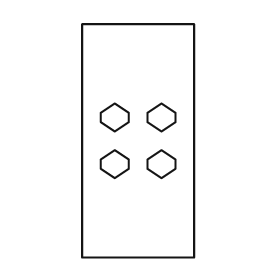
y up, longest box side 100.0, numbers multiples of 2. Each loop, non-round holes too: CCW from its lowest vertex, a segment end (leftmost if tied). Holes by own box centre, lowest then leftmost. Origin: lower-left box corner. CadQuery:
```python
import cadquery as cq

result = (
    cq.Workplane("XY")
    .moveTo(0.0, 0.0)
    .lineTo(48.0, 0.0)
    .lineTo(48.0, 100.0)
    .lineTo(0.0, 100.0)
    .close()
    .moveTo(14.0, 34.0)
    .lineTo(20.0, 38.0)
    .lineTo(20.0, 42.0)
    .lineTo(14.0, 46.0)
    .lineTo(8.0, 42.0)
    .lineTo(8.0, 38.0)
    .close()
    .moveTo(34.0, 34.0)
    .lineTo(40.0, 38.0)
    .lineTo(40.0, 42.0)
    .lineTo(34.0, 46.0)
    .lineTo(28.0, 42.0)
    .lineTo(28.0, 38.0)
    .close()
    .moveTo(14.0, 54.0)
    .lineTo(20.0, 58.0)
    .lineTo(20.0, 62.0)
    .lineTo(14.0, 66.0)
    .lineTo(8.0, 62.0)
    .lineTo(8.0, 58.0)
    .close()
    .moveTo(34.0, 54.0)
    .lineTo(40.0, 58.0)
    .lineTo(40.0, 62.0)
    .lineTo(34.0, 66.0)
    .lineTo(28.0, 62.0)
    .lineTo(28.0, 58.0)
    .close()
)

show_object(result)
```